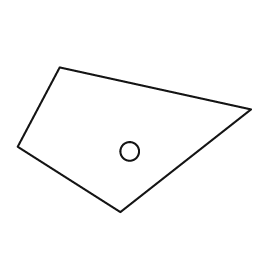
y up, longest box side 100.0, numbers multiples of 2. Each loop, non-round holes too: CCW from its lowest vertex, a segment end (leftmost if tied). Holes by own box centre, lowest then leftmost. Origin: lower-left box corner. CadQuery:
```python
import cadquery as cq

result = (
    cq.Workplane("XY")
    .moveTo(44.0, 0.0)
    .lineTo(100.0, 44.0)
    .lineTo(18.0, 62.0)
    .lineTo(0.0, 28.0)
    .close()
    .moveTo(48.0, 26.0)
    .circle(4.0)
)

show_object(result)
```